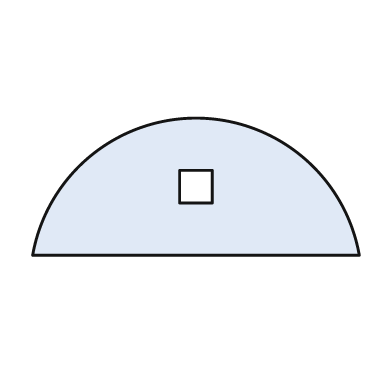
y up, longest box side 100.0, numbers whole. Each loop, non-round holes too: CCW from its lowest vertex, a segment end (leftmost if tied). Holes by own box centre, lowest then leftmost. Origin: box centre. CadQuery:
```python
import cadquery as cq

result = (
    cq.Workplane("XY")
    .moveTo(-50.0, -21.0)
    .lineTo(50.0, -21.0)
    .threePointArc((0.0, 21.0), (-50.0, -21.0))
    .close()
    .moveTo(-5.0, -5.0)
    .lineTo(5.0, -5.0)
    .lineTo(5.0, 5.0)
    .lineTo(-5.0, 5.0)
    .close()
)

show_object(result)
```